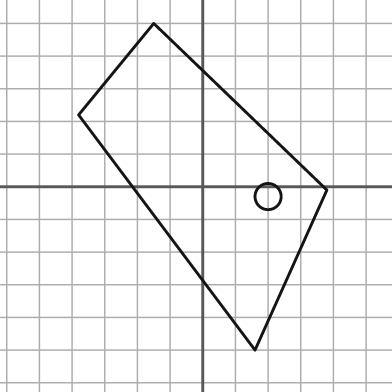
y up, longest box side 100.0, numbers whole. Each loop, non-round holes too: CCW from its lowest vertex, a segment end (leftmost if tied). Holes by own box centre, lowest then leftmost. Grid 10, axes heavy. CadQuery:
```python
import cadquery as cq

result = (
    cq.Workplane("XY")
    .moveTo(16.0, -50.0)
    .lineTo(38.0, -1.0)
    .lineTo(-15.0, 50.0)
    .lineTo(-38.0, 22.0)
    .close()
    .moveTo(20.0, -3.0)
    .circle(4.0)
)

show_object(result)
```